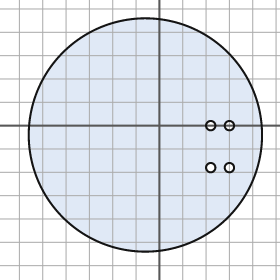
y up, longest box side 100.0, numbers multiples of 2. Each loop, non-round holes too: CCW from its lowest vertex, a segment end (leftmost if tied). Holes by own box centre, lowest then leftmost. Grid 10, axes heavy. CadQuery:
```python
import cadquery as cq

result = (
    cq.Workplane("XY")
    .moveTo(-6.0, -4.0)
    .circle(50.0)
    .moveTo(22.0, -18.0)
    .circle(2.0)
    .moveTo(30.0, -18.0)
    .circle(2.0)
    .moveTo(22.0, 0.0)
    .circle(2.0)
    .moveTo(30.0, 0.0)
    .circle(2.0)
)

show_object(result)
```